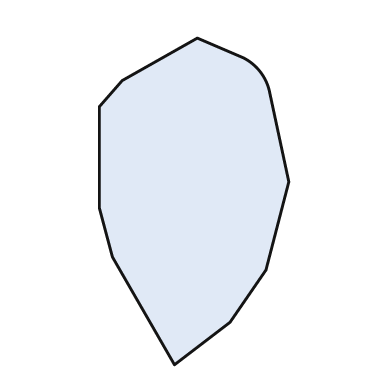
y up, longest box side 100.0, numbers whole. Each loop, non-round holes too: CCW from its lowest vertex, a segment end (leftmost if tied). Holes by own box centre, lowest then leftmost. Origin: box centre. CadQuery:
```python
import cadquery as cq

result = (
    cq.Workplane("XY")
    .moveTo(-6.0, -50.0)
    .lineTo(11.0, -37.0)
    .lineTo(22.0, -21.0)
    .lineTo(29.0, 6.0)
    .lineTo(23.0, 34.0)
    .threePointArc((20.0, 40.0), (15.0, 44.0))
    .lineTo(1.0, 50.0)
    .lineTo(-22.0, 37.0)
    .lineTo(-29.0, 29.0)
    .lineTo(-29.0, -2.0)
    .lineTo(-25.0, -17.0)
    .close()
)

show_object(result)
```